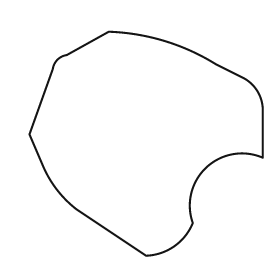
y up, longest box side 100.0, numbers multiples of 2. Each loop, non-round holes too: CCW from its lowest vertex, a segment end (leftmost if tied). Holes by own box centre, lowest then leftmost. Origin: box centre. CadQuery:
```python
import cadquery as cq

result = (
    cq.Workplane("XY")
    .moveTo(0.0, -48.0)
    .threePointArc((12.0, -44.0), (20.0, -34.0))
    .threePointArc((26.0, -10.0), (50.0, -6.0))
    .lineTo(50.0, 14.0)
    .threePointArc((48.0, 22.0), (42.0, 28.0))
    .lineTo(30.0, 34.0)
    .threePointArc((8.0, 44.0), (-16.0, 48.0))
    .lineTo(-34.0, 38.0)
    .threePointArc((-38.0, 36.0), (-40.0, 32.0))
    .lineTo(-50.0, 4.0)
    .lineTo(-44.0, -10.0)
    .threePointArc((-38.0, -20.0), (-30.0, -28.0))
    .close()
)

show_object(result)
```